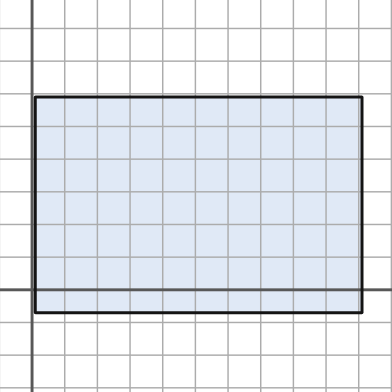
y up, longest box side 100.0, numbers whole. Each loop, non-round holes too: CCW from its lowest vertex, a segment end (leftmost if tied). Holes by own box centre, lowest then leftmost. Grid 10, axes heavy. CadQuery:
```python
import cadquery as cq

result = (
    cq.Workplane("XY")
    .moveTo(1.0, -7.0)
    .lineTo(101.0, -7.0)
    .lineTo(101.0, 59.0)
    .lineTo(1.0, 59.0)
    .close()
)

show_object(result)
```